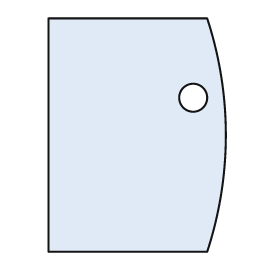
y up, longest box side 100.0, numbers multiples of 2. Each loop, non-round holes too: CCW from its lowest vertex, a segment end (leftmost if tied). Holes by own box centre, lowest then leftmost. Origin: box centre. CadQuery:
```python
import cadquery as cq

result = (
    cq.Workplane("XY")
    .moveTo(-38.0, -50.0)
    .lineTo(30.0, -50.0)
    .threePointArc((38.0, 0.0), (30.0, 50.0))
    .lineTo(-38.0, 50.0)
    .close()
    .moveTo(24.0, 16.0)
    .circle(6.0)
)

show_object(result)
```